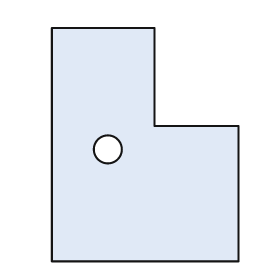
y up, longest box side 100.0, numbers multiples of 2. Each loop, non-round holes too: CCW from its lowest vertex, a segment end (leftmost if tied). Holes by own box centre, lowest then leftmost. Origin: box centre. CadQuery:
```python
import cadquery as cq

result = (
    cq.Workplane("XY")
    .moveTo(-40.0, -50.0)
    .lineTo(40.0, -50.0)
    .lineTo(40.0, 8.0)
    .lineTo(4.0, 8.0)
    .lineTo(4.0, 50.0)
    .lineTo(-40.0, 50.0)
    .close()
    .moveTo(-16.0, -2.0)
    .circle(6.0)
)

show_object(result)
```